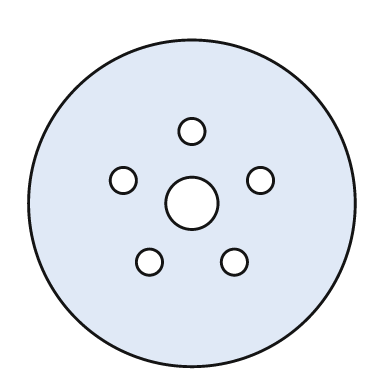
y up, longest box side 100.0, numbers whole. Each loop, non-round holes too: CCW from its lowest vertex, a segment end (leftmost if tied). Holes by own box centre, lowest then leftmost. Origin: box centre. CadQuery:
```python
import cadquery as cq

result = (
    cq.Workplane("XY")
    .moveTo(0.0, 0.0)
    .circle(50.0)
    .moveTo(-13.0, -18.0)
    .circle(4.0)
    .moveTo(13.0, -18.0)
    .circle(4.0)
    .moveTo(0.0, 0.0)
    .circle(8.0)
    .moveTo(-21.0, 7.0)
    .circle(4.0)
    .moveTo(21.0, 7.0)
    .circle(4.0)
    .moveTo(0.0, 22.0)
    .circle(4.0)
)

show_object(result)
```